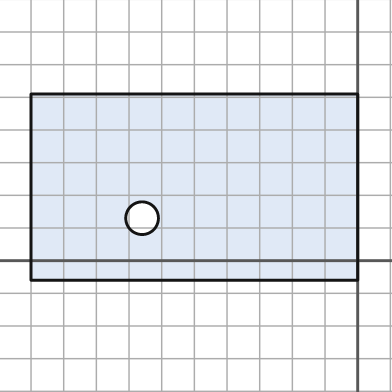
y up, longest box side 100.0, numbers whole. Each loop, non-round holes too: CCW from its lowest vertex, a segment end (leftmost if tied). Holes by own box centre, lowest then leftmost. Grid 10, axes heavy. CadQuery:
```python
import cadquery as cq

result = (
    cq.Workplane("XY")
    .moveTo(-100.0, -6.0)
    .lineTo(0.0, -6.0)
    .lineTo(0.0, 51.0)
    .lineTo(-100.0, 51.0)
    .close()
    .moveTo(-66.0, 13.0)
    .circle(5.0)
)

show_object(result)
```